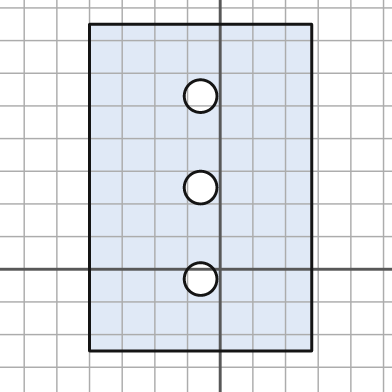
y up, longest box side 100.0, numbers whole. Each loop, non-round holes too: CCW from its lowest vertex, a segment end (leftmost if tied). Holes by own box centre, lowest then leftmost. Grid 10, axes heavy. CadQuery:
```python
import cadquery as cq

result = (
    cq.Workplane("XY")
    .moveTo(-40.0, -25.0)
    .lineTo(28.0, -25.0)
    .lineTo(28.0, 75.0)
    .lineTo(-40.0, 75.0)
    .close()
    .moveTo(-6.0, -3.0)
    .circle(5.0)
    .moveTo(-6.0, 25.0)
    .circle(5.0)
    .moveTo(-6.0, 53.0)
    .circle(5.0)
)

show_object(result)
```